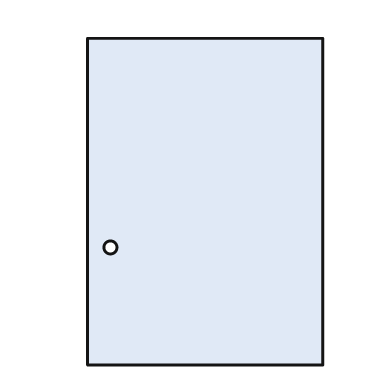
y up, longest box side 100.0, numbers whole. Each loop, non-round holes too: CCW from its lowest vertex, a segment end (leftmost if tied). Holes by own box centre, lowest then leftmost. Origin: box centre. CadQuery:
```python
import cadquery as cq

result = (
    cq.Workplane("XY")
    .moveTo(-36.0, -50.0)
    .lineTo(36.0, -50.0)
    .lineTo(36.0, 50.0)
    .lineTo(-36.0, 50.0)
    .close()
    .moveTo(-29.0, -14.0)
    .circle(2.0)
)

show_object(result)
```